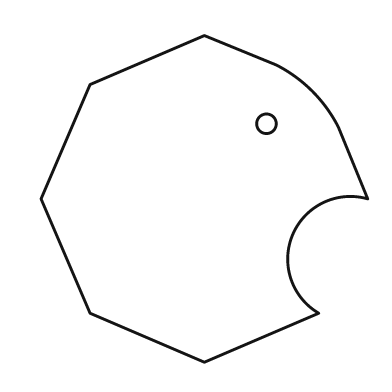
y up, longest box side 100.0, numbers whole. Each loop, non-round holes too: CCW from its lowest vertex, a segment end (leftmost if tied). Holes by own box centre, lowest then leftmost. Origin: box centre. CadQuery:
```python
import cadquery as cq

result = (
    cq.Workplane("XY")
    .moveTo(0.0, -50.0)
    .lineTo(35.0, -35.0)
    .threePointArc((27.0, -11.0), (50.0, 0.0))
    .lineTo(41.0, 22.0)
    .threePointArc((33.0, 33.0), (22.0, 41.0))
    .lineTo(0.0, 50.0)
    .lineTo(-35.0, 35.0)
    .lineTo(-50.0, 0.0)
    .lineTo(-35.0, -35.0)
    .close()
    .moveTo(19.0, 23.0)
    .circle(3.0)
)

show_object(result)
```